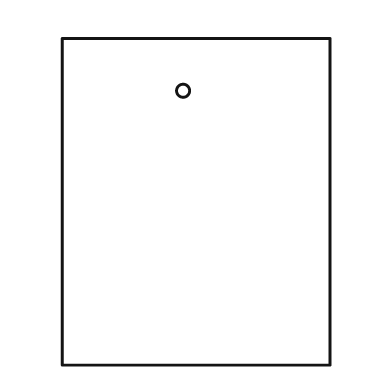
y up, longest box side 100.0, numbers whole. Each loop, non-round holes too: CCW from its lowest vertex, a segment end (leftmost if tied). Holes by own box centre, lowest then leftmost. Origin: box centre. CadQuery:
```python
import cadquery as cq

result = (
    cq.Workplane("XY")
    .moveTo(-41.0, -50.0)
    .lineTo(41.0, -50.0)
    .lineTo(41.0, 50.0)
    .lineTo(-41.0, 50.0)
    .close()
    .moveTo(-4.0, 34.0)
    .circle(2.0)
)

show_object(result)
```